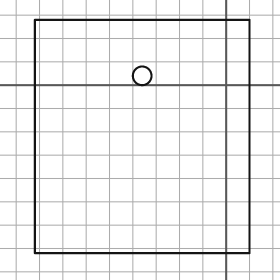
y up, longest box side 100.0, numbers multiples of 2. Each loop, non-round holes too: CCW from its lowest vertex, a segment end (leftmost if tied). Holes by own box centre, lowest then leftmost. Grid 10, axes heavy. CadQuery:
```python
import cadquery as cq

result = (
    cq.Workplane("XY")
    .moveTo(-82.0, -72.0)
    .lineTo(10.0, -72.0)
    .lineTo(10.0, 28.0)
    .lineTo(-82.0, 28.0)
    .close()
    .moveTo(-36.0, 4.0)
    .circle(4.0)
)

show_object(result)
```